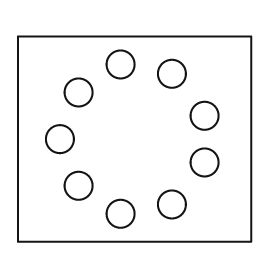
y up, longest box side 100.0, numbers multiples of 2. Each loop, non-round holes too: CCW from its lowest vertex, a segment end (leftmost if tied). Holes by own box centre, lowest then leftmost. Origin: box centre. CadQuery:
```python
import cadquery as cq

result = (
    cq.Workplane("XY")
    .moveTo(-50.0, -44.0)
    .lineTo(50.0, -44.0)
    .lineTo(50.0, 44.0)
    .lineTo(-50.0, 44.0)
    .close()
    .moveTo(-6.0, -32.0)
    .circle(6.0)
    .moveTo(16.0, -28.0)
    .circle(6.0)
    .moveTo(-24.0, -20.0)
    .circle(6.0)
    .moveTo(30.0, -10.0)
    .circle(6.0)
    .moveTo(-32.0, 0.0)
    .circle(6.0)
    .moveTo(30.0, 10.0)
    .circle(6.0)
    .moveTo(-24.0, 20.0)
    .circle(6.0)
    .moveTo(16.0, 28.0)
    .circle(6.0)
    .moveTo(-6.0, 32.0)
    .circle(6.0)
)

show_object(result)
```